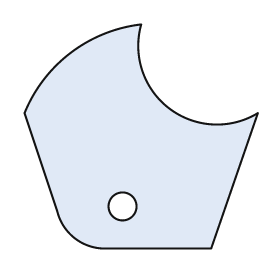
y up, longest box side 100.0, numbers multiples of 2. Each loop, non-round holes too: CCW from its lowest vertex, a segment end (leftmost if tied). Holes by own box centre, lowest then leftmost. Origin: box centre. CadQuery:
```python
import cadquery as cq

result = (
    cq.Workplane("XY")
    .moveTo(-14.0, -48.0)
    .lineTo(30.0, -48.0)
    .lineTo(50.0, 10.0)
    .threePointArc((12.0, 12.0), (0.0, 48.0))
    .threePointArc((-30.0, 36.0), (-50.0, 10.0))
    .lineTo(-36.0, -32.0)
    .threePointArc((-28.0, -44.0), (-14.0, -48.0))
    .close()
    .moveTo(-8.0, -30.0)
    .circle(6.0)
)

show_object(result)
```